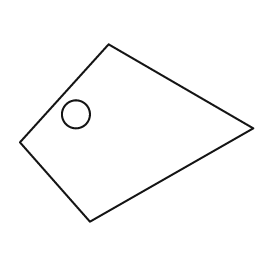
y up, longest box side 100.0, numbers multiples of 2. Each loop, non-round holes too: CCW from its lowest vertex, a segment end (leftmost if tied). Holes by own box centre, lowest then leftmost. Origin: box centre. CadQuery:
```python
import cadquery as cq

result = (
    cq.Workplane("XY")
    .moveTo(-20.0, -38.0)
    .lineTo(50.0, 2.0)
    .lineTo(-12.0, 38.0)
    .lineTo(-50.0, -4.0)
    .close()
    .moveTo(-26.0, 8.0)
    .circle(6.0)
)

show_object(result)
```